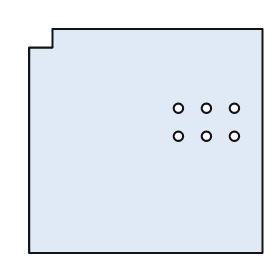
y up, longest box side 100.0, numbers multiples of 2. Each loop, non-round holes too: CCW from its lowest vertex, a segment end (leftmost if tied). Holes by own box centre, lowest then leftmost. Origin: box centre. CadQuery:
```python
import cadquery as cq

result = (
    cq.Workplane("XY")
    .moveTo(-50.0, -48.0)
    .lineTo(50.0, -48.0)
    .lineTo(50.0, 48.0)
    .lineTo(-40.0, 48.0)
    .lineTo(-40.0, 40.0)
    .lineTo(-50.0, 40.0)
    .close()
    .moveTo(14.0, 2.0)
    .circle(2.0)
    .moveTo(26.0, 2.0)
    .circle(2.0)
    .moveTo(38.0, 2.0)
    .circle(2.0)
    .moveTo(14.0, 14.0)
    .circle(2.0)
    .moveTo(26.0, 14.0)
    .circle(2.0)
    .moveTo(38.0, 14.0)
    .circle(2.0)
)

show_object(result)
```